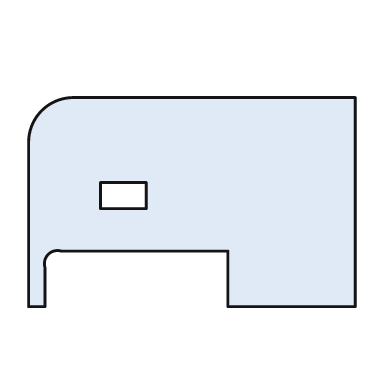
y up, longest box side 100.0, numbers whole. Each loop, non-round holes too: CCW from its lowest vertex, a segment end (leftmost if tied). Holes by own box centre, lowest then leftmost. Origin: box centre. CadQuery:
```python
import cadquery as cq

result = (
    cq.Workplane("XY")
    .moveTo(-50.0, -32.0)
    .lineTo(-45.0, -32.0)
    .lineTo(-45.0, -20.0)
    .threePointArc((-44.0, -16.0), (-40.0, -15.0))
    .lineTo(11.0, -15.0)
    .lineTo(11.0, -32.0)
    .lineTo(50.0, -32.0)
    .lineTo(50.0, 32.0)
    .lineTo(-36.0, 32.0)
    .threePointArc((-46.0, 28.0), (-50.0, 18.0))
    .close()
    .moveTo(-28.0, -2.0)
    .lineTo(-14.0, -2.0)
    .lineTo(-14.0, 6.0)
    .lineTo(-28.0, 6.0)
    .close()
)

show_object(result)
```